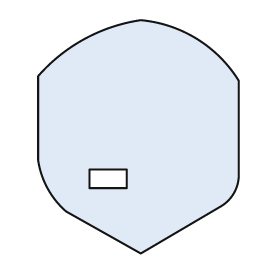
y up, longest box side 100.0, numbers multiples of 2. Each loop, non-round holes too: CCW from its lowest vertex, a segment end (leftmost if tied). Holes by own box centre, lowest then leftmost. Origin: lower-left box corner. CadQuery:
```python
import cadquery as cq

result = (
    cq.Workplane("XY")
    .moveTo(44.0, 0.0)
    .lineTo(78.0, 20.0)
    .threePointArc((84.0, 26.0), (86.0, 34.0))
    .lineTo(86.0, 74.0)
    .threePointArc((68.0, 92.0), (44.0, 100.0))
    .threePointArc((20.0, 92.0), (0.0, 76.0))
    .lineTo(0.0, 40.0)
    .threePointArc((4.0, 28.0), (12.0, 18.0))
    .close()
    .moveTo(22.0, 28.0)
    .lineTo(38.0, 28.0)
    .lineTo(38.0, 36.0)
    .lineTo(22.0, 36.0)
    .close()
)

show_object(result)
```